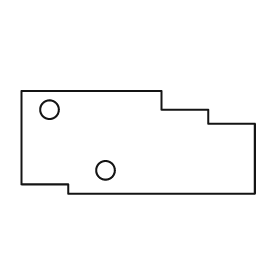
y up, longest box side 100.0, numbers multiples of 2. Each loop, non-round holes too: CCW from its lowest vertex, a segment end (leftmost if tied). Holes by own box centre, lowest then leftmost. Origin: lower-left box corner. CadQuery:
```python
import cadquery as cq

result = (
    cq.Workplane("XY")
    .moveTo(20.0, 0.0)
    .lineTo(100.0, 0.0)
    .lineTo(100.0, 30.0)
    .lineTo(80.0, 30.0)
    .lineTo(80.0, 36.0)
    .lineTo(60.0, 36.0)
    .lineTo(60.0, 44.0)
    .lineTo(0.0, 44.0)
    .lineTo(0.0, 4.0)
    .lineTo(20.0, 4.0)
    .close()
    .moveTo(36.0, 10.0)
    .circle(4.0)
    .moveTo(12.0, 36.0)
    .circle(4.0)
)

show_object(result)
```